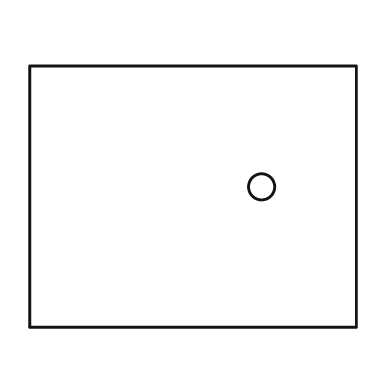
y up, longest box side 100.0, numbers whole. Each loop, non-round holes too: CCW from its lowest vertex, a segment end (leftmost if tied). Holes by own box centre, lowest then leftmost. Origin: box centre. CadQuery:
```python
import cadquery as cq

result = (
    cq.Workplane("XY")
    .moveTo(-50.0, -40.0)
    .lineTo(50.0, -40.0)
    .lineTo(50.0, 40.0)
    .lineTo(-50.0, 40.0)
    .close()
    .moveTo(21.0, 3.0)
    .circle(4.0)
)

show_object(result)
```